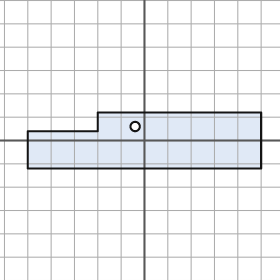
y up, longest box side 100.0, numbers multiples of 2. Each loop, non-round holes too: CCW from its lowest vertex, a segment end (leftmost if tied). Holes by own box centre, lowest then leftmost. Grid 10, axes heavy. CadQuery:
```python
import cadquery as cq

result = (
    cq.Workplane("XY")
    .moveTo(-50.0, -12.0)
    .lineTo(50.0, -12.0)
    .lineTo(50.0, 12.0)
    .lineTo(-20.0, 12.0)
    .lineTo(-20.0, 4.0)
    .lineTo(-50.0, 4.0)
    .close()
    .moveTo(-4.0, 6.0)
    .circle(2.0)
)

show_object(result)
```